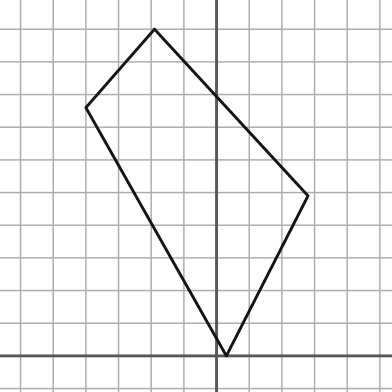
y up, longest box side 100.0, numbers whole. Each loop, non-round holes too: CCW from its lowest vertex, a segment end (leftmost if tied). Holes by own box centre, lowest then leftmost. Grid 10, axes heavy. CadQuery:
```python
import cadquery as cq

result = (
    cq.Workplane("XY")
    .moveTo(3.0, 0.0)
    .lineTo(28.0, 49.0)
    .lineTo(-19.0, 100.0)
    .lineTo(-40.0, 76.0)
    .close()
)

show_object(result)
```